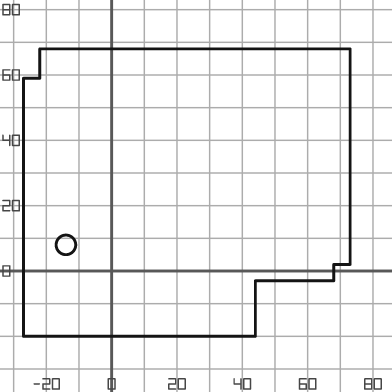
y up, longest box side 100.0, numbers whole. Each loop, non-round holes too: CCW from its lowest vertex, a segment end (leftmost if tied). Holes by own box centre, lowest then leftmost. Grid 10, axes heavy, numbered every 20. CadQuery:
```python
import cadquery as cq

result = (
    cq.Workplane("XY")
    .moveTo(-27.0, -20.0)
    .lineTo(44.0, -20.0)
    .lineTo(44.0, -3.0)
    .lineTo(68.0, -3.0)
    .lineTo(68.0, 2.0)
    .lineTo(73.0, 2.0)
    .lineTo(73.0, 68.0)
    .lineTo(-22.0, 68.0)
    .lineTo(-22.0, 59.0)
    .lineTo(-27.0, 59.0)
    .close()
    .moveTo(-14.0, 8.0)
    .circle(3.0)
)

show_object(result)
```